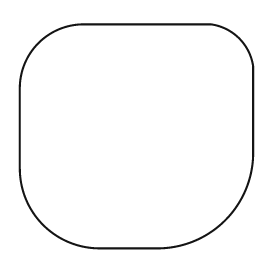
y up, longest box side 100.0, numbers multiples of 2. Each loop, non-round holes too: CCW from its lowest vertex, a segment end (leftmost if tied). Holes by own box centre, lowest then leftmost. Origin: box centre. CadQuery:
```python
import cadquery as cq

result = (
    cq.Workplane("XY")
    .moveTo(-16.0, -48.0)
    .lineTo(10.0, -48.0)
    .threePointArc((38.0, -36.0), (50.0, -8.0))
    .lineTo(50.0, 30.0)
    .threePointArc((44.0, 42.0), (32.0, 48.0))
    .lineTo(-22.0, 48.0)
    .threePointArc((-42.0, 40.0), (-50.0, 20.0))
    .lineTo(-50.0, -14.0)
    .threePointArc((-40.0, -38.0), (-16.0, -48.0))
    .close()
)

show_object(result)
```